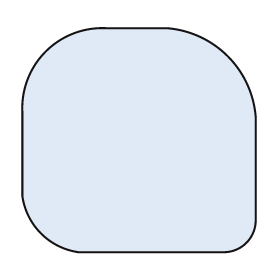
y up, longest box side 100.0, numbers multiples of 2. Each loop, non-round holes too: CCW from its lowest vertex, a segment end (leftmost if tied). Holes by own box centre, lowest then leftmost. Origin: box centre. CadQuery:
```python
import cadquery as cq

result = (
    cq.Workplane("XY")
    .moveTo(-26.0, -48.0)
    .lineTo(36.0, -48.0)
    .threePointArc((46.0, -44.0), (50.0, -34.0))
    .lineTo(50.0, 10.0)
    .threePointArc((38.0, 36.0), (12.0, 48.0))
    .lineTo(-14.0, 48.0)
    .threePointArc((-40.0, 38.0), (-50.0, 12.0))
    .lineTo(-50.0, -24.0)
    .threePointArc((-42.0, -40.0), (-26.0, -48.0))
    .close()
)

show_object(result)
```